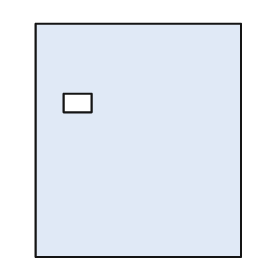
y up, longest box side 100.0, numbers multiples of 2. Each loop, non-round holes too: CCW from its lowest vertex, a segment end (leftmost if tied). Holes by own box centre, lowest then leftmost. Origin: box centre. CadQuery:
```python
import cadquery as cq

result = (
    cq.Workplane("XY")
    .moveTo(-44.0, -50.0)
    .lineTo(44.0, -50.0)
    .lineTo(44.0, 50.0)
    .lineTo(-44.0, 50.0)
    .close()
    .moveTo(-32.0, 12.0)
    .lineTo(-20.0, 12.0)
    .lineTo(-20.0, 20.0)
    .lineTo(-32.0, 20.0)
    .close()
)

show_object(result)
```